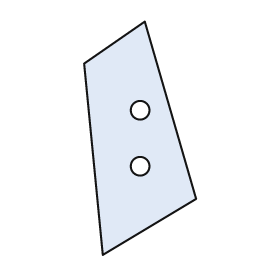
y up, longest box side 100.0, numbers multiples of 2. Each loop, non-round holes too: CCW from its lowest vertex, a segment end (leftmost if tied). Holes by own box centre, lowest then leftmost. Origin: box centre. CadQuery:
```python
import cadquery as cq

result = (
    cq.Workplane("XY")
    .moveTo(-16.0, -50.0)
    .lineTo(24.0, -26.0)
    .lineTo(2.0, 50.0)
    .lineTo(-24.0, 32.0)
    .close()
    .moveTo(0.0, -12.0)
    .circle(4.0)
    .moveTo(0.0, 12.0)
    .circle(4.0)
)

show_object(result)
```